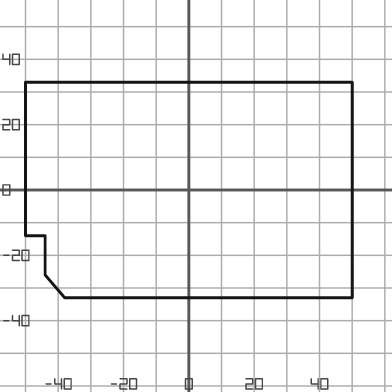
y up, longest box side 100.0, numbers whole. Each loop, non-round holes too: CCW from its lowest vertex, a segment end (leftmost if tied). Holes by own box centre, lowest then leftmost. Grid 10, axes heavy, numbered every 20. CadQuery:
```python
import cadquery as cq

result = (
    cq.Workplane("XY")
    .moveTo(-38.0, -33.0)
    .lineTo(50.0, -33.0)
    .lineTo(50.0, 33.0)
    .lineTo(-50.0, 33.0)
    .lineTo(-50.0, -14.0)
    .lineTo(-44.0, -14.0)
    .lineTo(-44.0, -26.0)
    .close()
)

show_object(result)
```